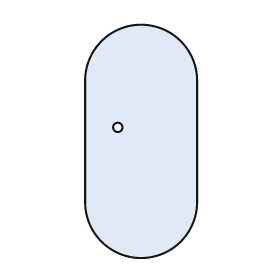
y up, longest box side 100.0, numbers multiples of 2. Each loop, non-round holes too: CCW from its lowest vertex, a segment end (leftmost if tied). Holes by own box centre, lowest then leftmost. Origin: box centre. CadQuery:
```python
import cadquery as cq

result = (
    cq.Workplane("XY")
    .moveTo(-24.0, -26.0)
    .threePointArc((0.0, -50.0), (24.0, -26.0))
    .lineTo(24.0, 26.0)
    .threePointArc((0.0, 50.0), (-24.0, 26.0))
    .close()
    .moveTo(-10.0, 6.0)
    .circle(2.0)
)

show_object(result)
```